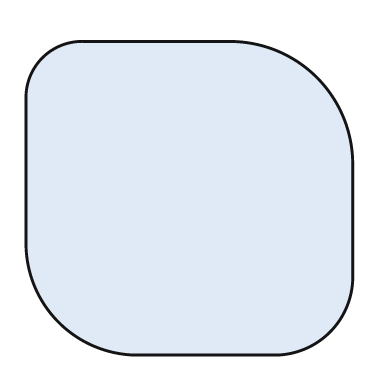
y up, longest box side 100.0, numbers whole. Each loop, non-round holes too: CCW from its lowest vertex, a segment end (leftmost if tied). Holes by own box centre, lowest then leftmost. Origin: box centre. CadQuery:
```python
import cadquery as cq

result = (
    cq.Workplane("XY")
    .moveTo(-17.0, -48.0)
    .lineTo(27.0, -48.0)
    .threePointArc((43.0, -41.0), (50.0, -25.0))
    .lineTo(50.0, 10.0)
    .threePointArc((39.0, 37.0), (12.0, 48.0))
    .lineTo(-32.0, 48.0)
    .threePointArc((-45.0, 43.0), (-50.0, 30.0))
    .lineTo(-50.0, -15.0)
    .threePointArc((-40.0, -38.0), (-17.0, -48.0))
    .close()
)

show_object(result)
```